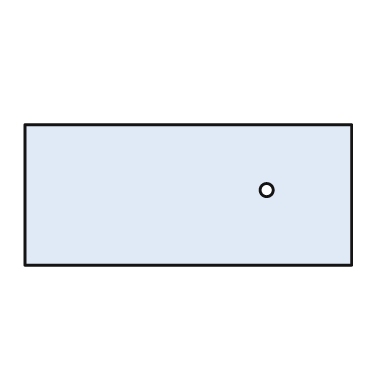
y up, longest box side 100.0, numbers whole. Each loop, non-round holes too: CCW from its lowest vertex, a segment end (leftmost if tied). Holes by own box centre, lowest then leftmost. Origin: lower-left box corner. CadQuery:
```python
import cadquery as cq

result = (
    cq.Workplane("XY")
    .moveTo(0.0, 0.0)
    .lineTo(100.0, 0.0)
    .lineTo(100.0, 43.0)
    .lineTo(0.0, 43.0)
    .close()
    .moveTo(74.0, 23.0)
    .circle(2.0)
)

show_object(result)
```